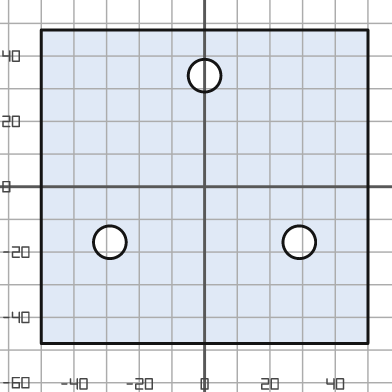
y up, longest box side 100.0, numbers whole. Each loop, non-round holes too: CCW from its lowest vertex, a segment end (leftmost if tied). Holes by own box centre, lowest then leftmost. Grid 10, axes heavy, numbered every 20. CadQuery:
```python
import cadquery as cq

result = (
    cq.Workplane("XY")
    .moveTo(-50.0, -48.0)
    .lineTo(50.0, -48.0)
    .lineTo(50.0, 48.0)
    .lineTo(-50.0, 48.0)
    .close()
    .moveTo(-29.0, -17.0)
    .circle(5.0)
    .moveTo(29.0, -17.0)
    .circle(5.0)
    .moveTo(0.0, 34.0)
    .circle(5.0)
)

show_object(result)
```